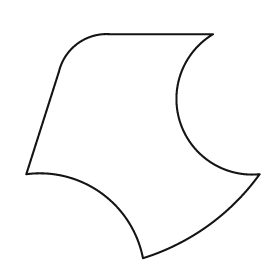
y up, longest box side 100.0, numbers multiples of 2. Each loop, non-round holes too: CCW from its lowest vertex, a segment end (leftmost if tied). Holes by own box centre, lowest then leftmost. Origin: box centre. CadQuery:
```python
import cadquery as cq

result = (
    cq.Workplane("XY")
    .moveTo(0.0, -48.0)
    .threePointArc((28.0, -34.0), (50.0, -12.0))
    .threePointArc((16.0, 10.0), (30.0, 48.0))
    .lineTo(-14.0, 48.0)
    .threePointArc((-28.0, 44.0), (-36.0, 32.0))
    .lineTo(-50.0, -12.0)
    .threePointArc((-18.0, -20.0), (0.0, -48.0))
    .close()
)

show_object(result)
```